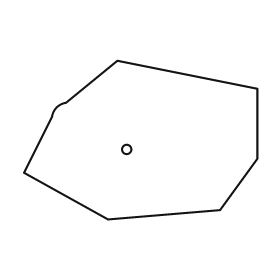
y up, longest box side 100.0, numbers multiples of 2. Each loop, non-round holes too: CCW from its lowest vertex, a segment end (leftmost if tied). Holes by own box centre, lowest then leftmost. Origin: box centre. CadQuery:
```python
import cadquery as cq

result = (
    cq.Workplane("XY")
    .moveTo(-14.0, -34.0)
    .lineTo(34.0, -30.0)
    .lineTo(50.0, -8.0)
    .lineTo(50.0, 22.0)
    .lineTo(-10.0, 34.0)
    .lineTo(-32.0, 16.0)
    .threePointArc((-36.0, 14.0), (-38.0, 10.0))
    .lineTo(-50.0, -14.0)
    .close()
    .moveTo(-6.0, -4.0)
    .circle(2.0)
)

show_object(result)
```